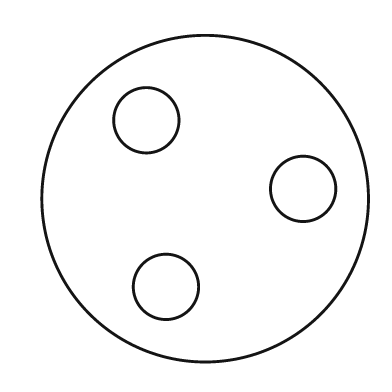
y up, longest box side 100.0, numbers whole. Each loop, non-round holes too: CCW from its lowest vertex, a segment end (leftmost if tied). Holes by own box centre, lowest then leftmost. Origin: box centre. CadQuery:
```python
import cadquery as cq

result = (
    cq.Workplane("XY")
    .moveTo(0.0, 0.0)
    .circle(50.0)
    .moveTo(-12.0, -27.0)
    .circle(10.0)
    .moveTo(30.0, 3.0)
    .circle(10.0)
    .moveTo(-18.0, 24.0)
    .circle(10.0)
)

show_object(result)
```